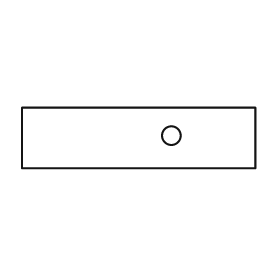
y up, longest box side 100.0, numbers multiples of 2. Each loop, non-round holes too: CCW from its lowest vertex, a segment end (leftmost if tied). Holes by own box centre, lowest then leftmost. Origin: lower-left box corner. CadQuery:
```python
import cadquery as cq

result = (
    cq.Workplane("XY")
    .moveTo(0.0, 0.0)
    .lineTo(100.0, 0.0)
    .lineTo(100.0, 26.0)
    .lineTo(0.0, 26.0)
    .close()
    .moveTo(64.0, 14.0)
    .circle(4.0)
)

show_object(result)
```